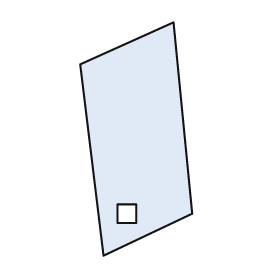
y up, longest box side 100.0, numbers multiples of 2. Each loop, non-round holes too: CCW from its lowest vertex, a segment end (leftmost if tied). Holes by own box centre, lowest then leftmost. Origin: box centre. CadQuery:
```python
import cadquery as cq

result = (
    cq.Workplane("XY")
    .moveTo(-14.0, -50.0)
    .lineTo(24.0, -32.0)
    .lineTo(16.0, 50.0)
    .lineTo(-24.0, 32.0)
    .close()
    .moveTo(-8.0, -36.0)
    .lineTo(0.0, -36.0)
    .lineTo(0.0, -28.0)
    .lineTo(-8.0, -28.0)
    .close()
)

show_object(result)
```